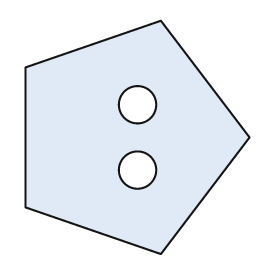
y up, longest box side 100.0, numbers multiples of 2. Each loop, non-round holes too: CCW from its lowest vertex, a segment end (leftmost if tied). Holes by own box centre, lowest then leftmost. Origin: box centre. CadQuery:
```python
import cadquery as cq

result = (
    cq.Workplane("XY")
    .moveTo(10.0, -50.0)
    .lineTo(48.0, 0.0)
    .lineTo(10.0, 50.0)
    .lineTo(-48.0, 30.0)
    .lineTo(-48.0, -30.0)
    .close()
    .moveTo(0.0, -14.0)
    .circle(8.0)
    .moveTo(0.0, 14.0)
    .circle(8.0)
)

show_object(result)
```